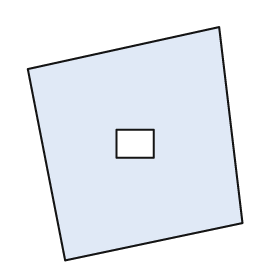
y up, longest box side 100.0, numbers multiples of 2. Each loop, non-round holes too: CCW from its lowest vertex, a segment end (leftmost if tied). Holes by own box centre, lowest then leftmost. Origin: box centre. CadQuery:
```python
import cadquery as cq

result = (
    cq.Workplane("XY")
    .moveTo(-30.0, -50.0)
    .lineTo(46.0, -34.0)
    .lineTo(36.0, 50.0)
    .lineTo(-46.0, 32.0)
    .close()
    .moveTo(-8.0, -6.0)
    .lineTo(8.0, -6.0)
    .lineTo(8.0, 6.0)
    .lineTo(-8.0, 6.0)
    .close()
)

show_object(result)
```